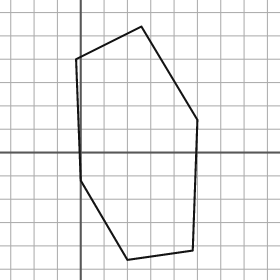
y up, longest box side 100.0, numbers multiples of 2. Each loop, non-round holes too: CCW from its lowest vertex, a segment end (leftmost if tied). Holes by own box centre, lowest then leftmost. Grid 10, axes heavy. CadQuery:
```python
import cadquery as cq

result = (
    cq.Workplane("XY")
    .moveTo(20.0, -46.0)
    .lineTo(48.0, -42.0)
    .lineTo(50.0, 14.0)
    .lineTo(26.0, 54.0)
    .lineTo(-2.0, 40.0)
    .lineTo(0.0, -12.0)
    .close()
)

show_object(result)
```